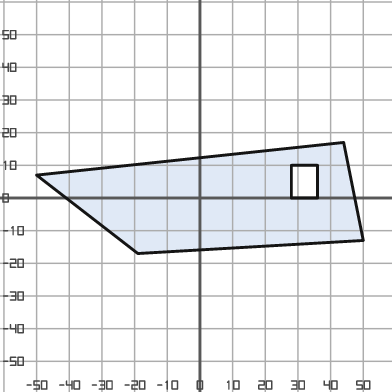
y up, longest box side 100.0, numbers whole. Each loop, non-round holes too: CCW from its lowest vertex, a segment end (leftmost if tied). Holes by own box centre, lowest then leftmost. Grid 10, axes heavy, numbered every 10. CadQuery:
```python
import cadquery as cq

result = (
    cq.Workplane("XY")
    .moveTo(-19.0, -17.0)
    .lineTo(50.0, -13.0)
    .lineTo(44.0, 17.0)
    .lineTo(-50.0, 7.0)
    .close()
    .moveTo(28.0, 0.0)
    .lineTo(36.0, 0.0)
    .lineTo(36.0, 10.0)
    .lineTo(28.0, 10.0)
    .close()
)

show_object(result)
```